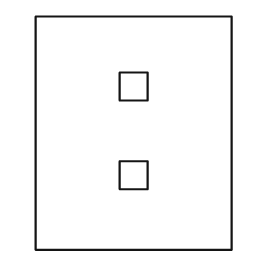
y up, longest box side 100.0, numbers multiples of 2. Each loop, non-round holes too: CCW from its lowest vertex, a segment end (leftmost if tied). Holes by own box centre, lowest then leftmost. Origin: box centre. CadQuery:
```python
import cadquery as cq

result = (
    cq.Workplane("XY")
    .moveTo(-42.0, -50.0)
    .lineTo(42.0, -50.0)
    .lineTo(42.0, 50.0)
    .lineTo(-42.0, 50.0)
    .close()
    .moveTo(-6.0, -24.0)
    .lineTo(6.0, -24.0)
    .lineTo(6.0, -12.0)
    .lineTo(-6.0, -12.0)
    .close()
    .moveTo(-6.0, 14.0)
    .lineTo(6.0, 14.0)
    .lineTo(6.0, 26.0)
    .lineTo(-6.0, 26.0)
    .close()
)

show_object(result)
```